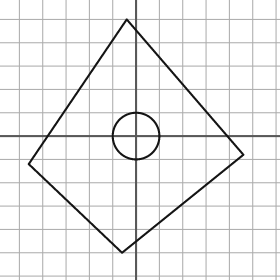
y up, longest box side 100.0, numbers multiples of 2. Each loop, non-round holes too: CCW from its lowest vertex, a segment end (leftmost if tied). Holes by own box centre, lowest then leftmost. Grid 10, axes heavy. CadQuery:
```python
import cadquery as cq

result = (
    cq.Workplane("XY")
    .moveTo(-6.0, -50.0)
    .lineTo(46.0, -8.0)
    .lineTo(-4.0, 50.0)
    .lineTo(-46.0, -12.0)
    .close()
    .moveTo(0.0, 0.0)
    .circle(10.0)
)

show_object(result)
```